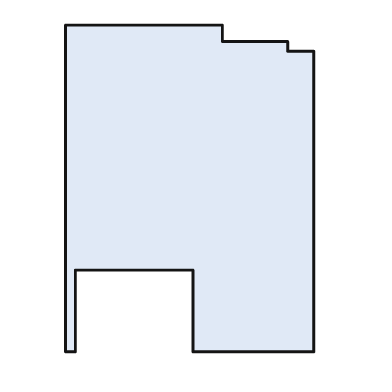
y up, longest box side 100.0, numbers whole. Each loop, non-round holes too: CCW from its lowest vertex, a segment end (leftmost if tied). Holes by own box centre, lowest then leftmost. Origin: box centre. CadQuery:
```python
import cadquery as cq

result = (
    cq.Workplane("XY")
    .moveTo(-38.0, -50.0)
    .lineTo(-35.0, -50.0)
    .lineTo(-35.0, -25.0)
    .lineTo(1.0, -25.0)
    .lineTo(1.0, -50.0)
    .lineTo(38.0, -50.0)
    .lineTo(38.0, 42.0)
    .lineTo(30.0, 42.0)
    .lineTo(30.0, 45.0)
    .lineTo(10.0, 45.0)
    .lineTo(10.0, 50.0)
    .lineTo(-38.0, 50.0)
    .close()
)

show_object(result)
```